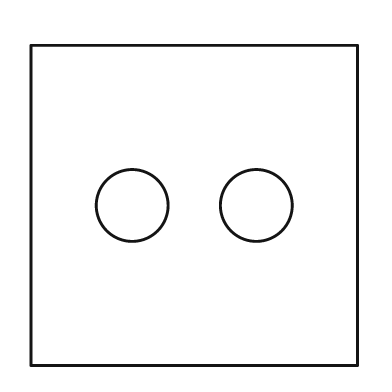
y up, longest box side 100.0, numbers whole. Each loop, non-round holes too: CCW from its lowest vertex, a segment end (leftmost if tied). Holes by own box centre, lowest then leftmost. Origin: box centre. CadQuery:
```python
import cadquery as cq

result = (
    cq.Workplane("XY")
    .moveTo(-50.0, -49.0)
    .lineTo(50.0, -49.0)
    .lineTo(50.0, 49.0)
    .lineTo(-50.0, 49.0)
    .close()
    .moveTo(-19.0, 0.0)
    .circle(11.0)
    .moveTo(19.0, 0.0)
    .circle(11.0)
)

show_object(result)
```